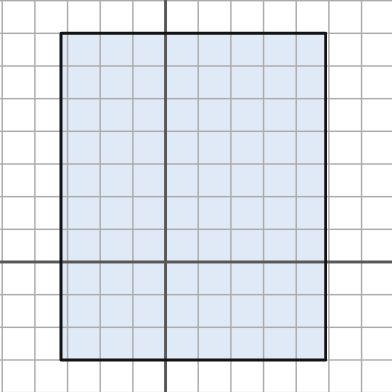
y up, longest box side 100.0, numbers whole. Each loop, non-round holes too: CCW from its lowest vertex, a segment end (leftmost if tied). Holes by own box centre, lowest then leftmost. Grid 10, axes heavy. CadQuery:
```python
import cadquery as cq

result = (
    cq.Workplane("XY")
    .moveTo(-32.0, -30.0)
    .lineTo(49.0, -30.0)
    .lineTo(49.0, 70.0)
    .lineTo(-32.0, 70.0)
    .close()
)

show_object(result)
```